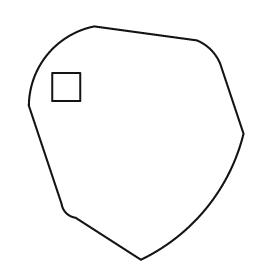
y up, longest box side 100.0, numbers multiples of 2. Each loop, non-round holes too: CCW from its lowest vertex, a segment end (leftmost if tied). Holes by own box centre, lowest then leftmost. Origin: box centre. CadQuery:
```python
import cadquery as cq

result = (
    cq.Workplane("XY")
    .moveTo(2.0, -50.0)
    .threePointArc((30.0, -28.0), (46.0, 4.0))
    .lineTo(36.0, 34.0)
    .threePointArc((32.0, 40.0), (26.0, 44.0))
    .lineTo(-18.0, 50.0)
    .threePointArc((-38.0, 38.0), (-46.0, 16.0))
    .lineTo(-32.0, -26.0)
    .threePointArc((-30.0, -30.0), (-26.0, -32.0))
    .close()
    .moveTo(-36.0, 18.0)
    .lineTo(-24.0, 18.0)
    .lineTo(-24.0, 30.0)
    .lineTo(-36.0, 30.0)
    .close()
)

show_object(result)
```